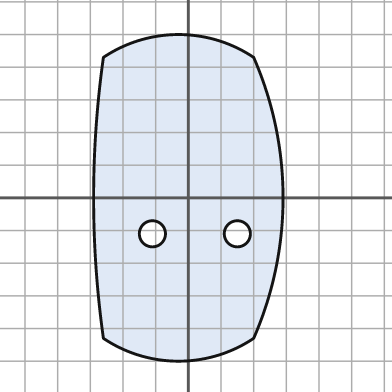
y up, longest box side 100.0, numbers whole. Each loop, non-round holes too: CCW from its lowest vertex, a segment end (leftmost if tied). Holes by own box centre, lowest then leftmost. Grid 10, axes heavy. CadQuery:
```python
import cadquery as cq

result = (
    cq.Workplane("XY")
    .moveTo(-26.0, -43.0)
    .threePointArc((-3.0, -50.0), (20.0, -43.0))
    .threePointArc((29.0, 0.0), (20.0, 43.0))
    .threePointArc((-3.0, 50.0), (-26.0, 43.0))
    .threePointArc((-29.0, 0.0), (-26.0, -43.0))
    .close()
    .moveTo(-11.0, -11.0)
    .circle(4.0)
    .moveTo(15.0, -11.0)
    .circle(4.0)
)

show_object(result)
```